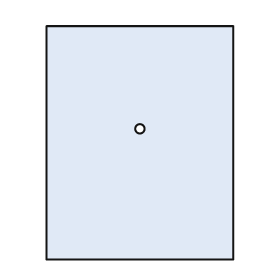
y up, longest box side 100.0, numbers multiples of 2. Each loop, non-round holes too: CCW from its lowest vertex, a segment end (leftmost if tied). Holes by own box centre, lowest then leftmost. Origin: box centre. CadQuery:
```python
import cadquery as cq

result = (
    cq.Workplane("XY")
    .moveTo(-40.0, -50.0)
    .lineTo(40.0, -50.0)
    .lineTo(40.0, 50.0)
    .lineTo(-40.0, 50.0)
    .close()
    .moveTo(0.0, 6.0)
    .circle(2.0)
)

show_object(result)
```